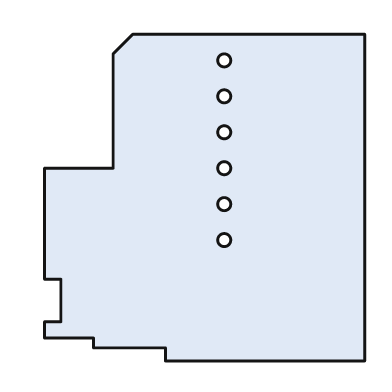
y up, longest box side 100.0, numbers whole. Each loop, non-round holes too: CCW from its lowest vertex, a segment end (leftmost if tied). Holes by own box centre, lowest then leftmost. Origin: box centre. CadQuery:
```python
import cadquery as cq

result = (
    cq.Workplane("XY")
    .moveTo(-12.0, -50.0)
    .lineTo(49.0, -50.0)
    .lineTo(49.0, 50.0)
    .lineTo(-22.0, 50.0)
    .lineTo(-28.0, 44.0)
    .lineTo(-28.0, 9.0)
    .lineTo(-49.0, 9.0)
    .lineTo(-49.0, -25.0)
    .lineTo(-44.0, -25.0)
    .lineTo(-44.0, -38.0)
    .lineTo(-49.0, -38.0)
    .lineTo(-49.0, -43.0)
    .lineTo(-34.0, -43.0)
    .lineTo(-34.0, -46.0)
    .lineTo(-12.0, -46.0)
    .close()
    .moveTo(6.0, -13.0)
    .circle(2.0)
    .moveTo(6.0, -2.0)
    .circle(2.0)
    .moveTo(6.0, 9.0)
    .circle(2.0)
    .moveTo(6.0, 20.0)
    .circle(2.0)
    .moveTo(6.0, 31.0)
    .circle(2.0)
    .moveTo(6.0, 42.0)
    .circle(2.0)
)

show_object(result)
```